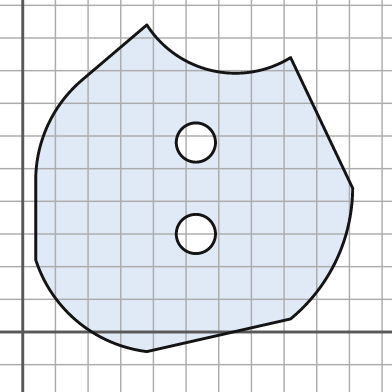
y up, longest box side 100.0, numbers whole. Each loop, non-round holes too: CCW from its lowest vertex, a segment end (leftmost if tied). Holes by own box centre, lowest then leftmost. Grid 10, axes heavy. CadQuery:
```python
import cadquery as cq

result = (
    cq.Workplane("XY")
    .moveTo(38.0, -6.0)
    .lineTo(82.0, 4.0)
    .threePointArc((96.0, 22.0), (101.0, 44.0))
    .lineTo(82.0, 84.0)
    .threePointArc((58.0, 80.0), (38.0, 94.0))
    .lineTo(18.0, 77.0)
    .threePointArc((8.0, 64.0), (4.0, 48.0))
    .lineTo(4.0, 22.0)
    .threePointArc((17.0, 3.0), (38.0, -6.0))
    .close()
    .moveTo(53.0, 30.0)
    .circle(6.0)
    .moveTo(53.0, 58.0)
    .circle(6.0)
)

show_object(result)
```